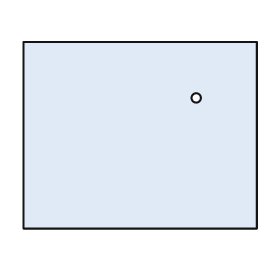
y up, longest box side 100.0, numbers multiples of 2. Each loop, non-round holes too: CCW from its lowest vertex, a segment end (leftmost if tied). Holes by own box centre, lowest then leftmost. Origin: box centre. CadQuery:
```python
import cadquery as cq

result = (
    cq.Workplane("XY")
    .moveTo(-50.0, -40.0)
    .lineTo(50.0, -40.0)
    .lineTo(50.0, 40.0)
    .lineTo(-50.0, 40.0)
    .close()
    .moveTo(24.0, 16.0)
    .circle(2.0)
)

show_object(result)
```